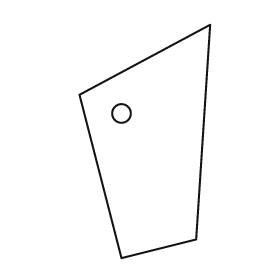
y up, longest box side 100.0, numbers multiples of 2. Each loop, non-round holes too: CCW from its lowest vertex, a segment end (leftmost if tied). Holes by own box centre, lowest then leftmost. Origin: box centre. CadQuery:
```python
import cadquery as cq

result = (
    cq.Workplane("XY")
    .moveTo(-10.0, -50.0)
    .lineTo(22.0, -42.0)
    .lineTo(28.0, 50.0)
    .lineTo(-28.0, 20.0)
    .close()
    .moveTo(-10.0, 12.0)
    .circle(4.0)
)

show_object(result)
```